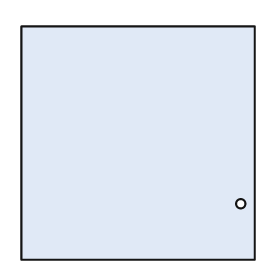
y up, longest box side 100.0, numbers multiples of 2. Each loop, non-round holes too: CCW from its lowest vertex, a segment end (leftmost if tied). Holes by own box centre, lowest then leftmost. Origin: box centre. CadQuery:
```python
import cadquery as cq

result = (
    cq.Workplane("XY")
    .moveTo(-50.0, -50.0)
    .lineTo(50.0, -50.0)
    .lineTo(50.0, 50.0)
    .lineTo(-50.0, 50.0)
    .close()
    .moveTo(44.0, -26.0)
    .circle(2.0)
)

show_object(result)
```